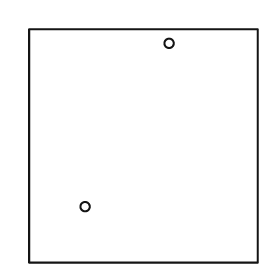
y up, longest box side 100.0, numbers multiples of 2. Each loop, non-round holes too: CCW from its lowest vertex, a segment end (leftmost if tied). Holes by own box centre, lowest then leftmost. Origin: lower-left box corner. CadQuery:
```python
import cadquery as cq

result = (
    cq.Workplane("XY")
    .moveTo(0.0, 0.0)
    .lineTo(98.0, 0.0)
    .lineTo(98.0, 100.0)
    .lineTo(0.0, 100.0)
    .close()
    .moveTo(24.0, 24.0)
    .circle(2.0)
    .moveTo(60.0, 94.0)
    .circle(2.0)
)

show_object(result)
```